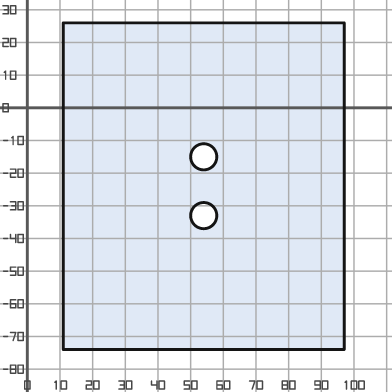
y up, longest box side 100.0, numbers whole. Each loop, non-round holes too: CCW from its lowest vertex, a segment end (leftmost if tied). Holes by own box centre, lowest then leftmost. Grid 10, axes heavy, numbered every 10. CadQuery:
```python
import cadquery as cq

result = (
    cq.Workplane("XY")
    .moveTo(11.0, -74.0)
    .lineTo(97.0, -74.0)
    .lineTo(97.0, 26.0)
    .lineTo(11.0, 26.0)
    .close()
    .moveTo(54.0, -33.0)
    .circle(4.0)
    .moveTo(54.0, -15.0)
    .circle(4.0)
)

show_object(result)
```